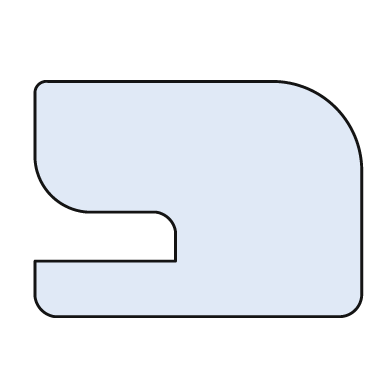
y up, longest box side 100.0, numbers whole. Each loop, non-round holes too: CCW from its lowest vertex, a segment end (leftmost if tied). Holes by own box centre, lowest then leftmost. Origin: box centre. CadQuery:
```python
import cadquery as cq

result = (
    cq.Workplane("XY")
    .moveTo(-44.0, -36.0)
    .lineTo(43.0, -36.0)
    .threePointArc((48.0, -34.0), (50.0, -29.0))
    .lineTo(50.0, 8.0)
    .threePointArc((42.0, 28.0), (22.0, 36.0))
    .lineTo(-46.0, 36.0)
    .threePointArc((-49.0, 35.0), (-50.0, 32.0))
    .lineTo(-50.0, 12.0)
    .threePointArc((-45.0, 1.0), (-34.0, -4.0))
    .lineTo(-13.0, -4.0)
    .threePointArc((-9.0, -6.0), (-7.0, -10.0))
    .lineTo(-7.0, -19.0)
    .lineTo(-50.0, -19.0)
    .lineTo(-50.0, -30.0)
    .threePointArc((-48.0, -34.0), (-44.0, -36.0))
    .close()
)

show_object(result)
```